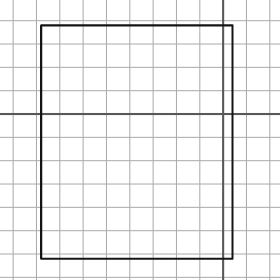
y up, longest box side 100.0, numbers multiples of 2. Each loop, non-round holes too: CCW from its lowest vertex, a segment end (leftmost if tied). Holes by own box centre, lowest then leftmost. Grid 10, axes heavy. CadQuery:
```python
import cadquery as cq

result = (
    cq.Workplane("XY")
    .moveTo(-78.0, -62.0)
    .lineTo(4.0, -62.0)
    .lineTo(4.0, 38.0)
    .lineTo(-78.0, 38.0)
    .close()
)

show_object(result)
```